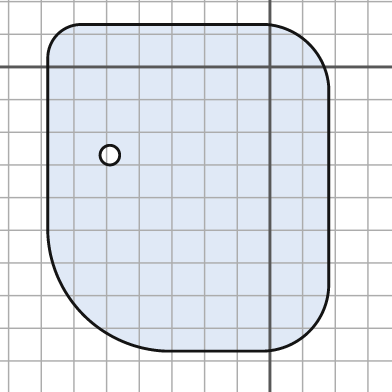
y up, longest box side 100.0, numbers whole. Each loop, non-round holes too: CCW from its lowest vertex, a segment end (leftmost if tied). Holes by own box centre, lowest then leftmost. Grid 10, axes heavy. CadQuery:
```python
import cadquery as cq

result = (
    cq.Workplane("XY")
    .moveTo(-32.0, -87.0)
    .lineTo(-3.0, -87.0)
    .threePointArc((12.0, -81.0), (18.0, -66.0))
    .lineTo(18.0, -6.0)
    .threePointArc((12.0, 7.0), (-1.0, 13.0))
    .lineTo(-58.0, 13.0)
    .threePointArc((-65.0, 10.0), (-68.0, 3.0))
    .lineTo(-68.0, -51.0)
    .threePointArc((-57.0, -76.0), (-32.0, -87.0))
    .close()
    .moveTo(-49.0, -27.0)
    .circle(3.0)
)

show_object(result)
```